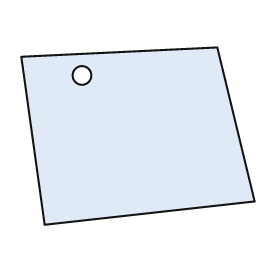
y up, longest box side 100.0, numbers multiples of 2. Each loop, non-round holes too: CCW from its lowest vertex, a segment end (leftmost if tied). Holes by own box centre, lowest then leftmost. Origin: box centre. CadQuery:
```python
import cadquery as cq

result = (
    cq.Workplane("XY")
    .moveTo(-40.0, -38.0)
    .lineTo(50.0, -28.0)
    .lineTo(34.0, 38.0)
    .lineTo(-50.0, 34.0)
    .close()
    .moveTo(-24.0, 26.0)
    .circle(4.0)
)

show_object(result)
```